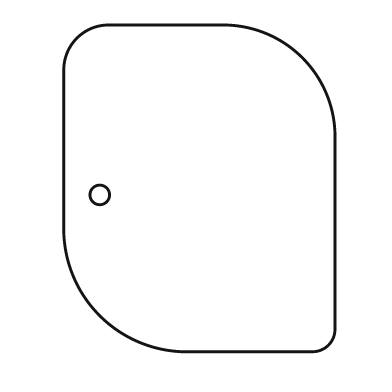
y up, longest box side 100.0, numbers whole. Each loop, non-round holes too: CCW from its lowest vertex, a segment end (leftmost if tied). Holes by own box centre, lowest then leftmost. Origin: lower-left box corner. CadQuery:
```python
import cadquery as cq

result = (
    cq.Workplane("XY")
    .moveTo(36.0, 0.0)
    .lineTo(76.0, 0.0)
    .threePointArc((81.0, 2.0), (83.0, 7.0))
    .lineTo(83.0, 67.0)
    .threePointArc((73.0, 90.0), (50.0, 100.0))
    .lineTo(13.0, 100.0)
    .threePointArc((4.0, 96.0), (0.0, 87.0))
    .lineTo(0.0, 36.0)
    .threePointArc((11.0, 11.0), (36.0, 0.0))
    .close()
    .moveTo(11.0, 48.0)
    .circle(3.0)
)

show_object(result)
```